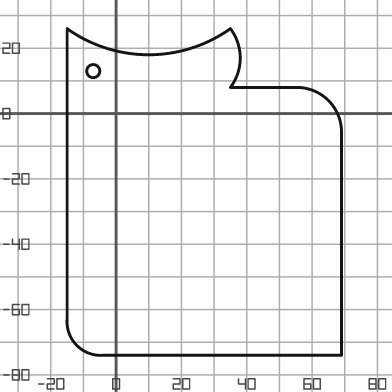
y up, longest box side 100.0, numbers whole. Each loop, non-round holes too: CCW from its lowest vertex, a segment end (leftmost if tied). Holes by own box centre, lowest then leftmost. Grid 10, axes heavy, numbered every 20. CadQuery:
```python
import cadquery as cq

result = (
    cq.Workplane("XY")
    .moveTo(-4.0, -74.0)
    .lineTo(69.0, -74.0)
    .lineTo(69.0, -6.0)
    .threePointArc((65.0, 4.0), (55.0, 8.0))
    .lineTo(35.0, 8.0)
    .threePointArc((38.0, 17.0), (35.0, 26.0))
    .threePointArc((10.0, 18.0), (-15.0, 26.0))
    .lineTo(-15.0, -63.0)
    .threePointArc((-12.0, -71.0), (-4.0, -74.0))
    .close()
    .moveTo(-7.0, 13.0)
    .circle(2.0)
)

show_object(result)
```